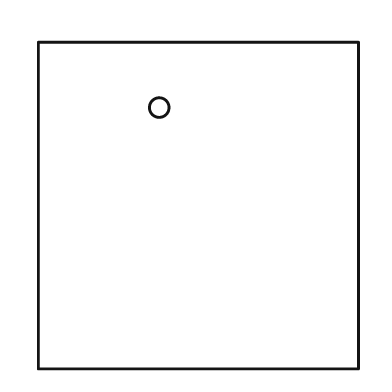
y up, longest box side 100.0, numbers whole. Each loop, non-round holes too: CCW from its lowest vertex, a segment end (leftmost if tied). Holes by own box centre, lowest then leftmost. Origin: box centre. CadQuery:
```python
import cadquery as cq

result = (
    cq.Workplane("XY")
    .moveTo(-49.0, -50.0)
    .lineTo(49.0, -50.0)
    .lineTo(49.0, 50.0)
    .lineTo(-49.0, 50.0)
    .close()
    .moveTo(-12.0, 30.0)
    .circle(3.0)
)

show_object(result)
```